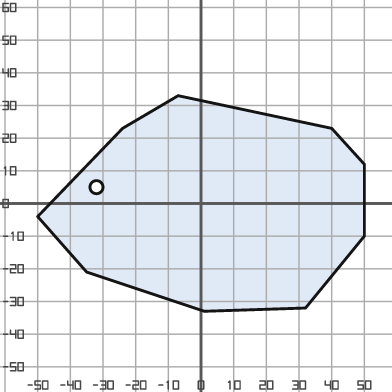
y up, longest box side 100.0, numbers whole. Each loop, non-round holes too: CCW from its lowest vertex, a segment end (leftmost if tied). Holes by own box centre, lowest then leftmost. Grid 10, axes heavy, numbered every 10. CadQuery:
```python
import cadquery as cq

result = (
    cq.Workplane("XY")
    .moveTo(1.0, -33.0)
    .lineTo(32.0, -32.0)
    .lineTo(50.0, -10.0)
    .lineTo(50.0, 12.0)
    .lineTo(40.0, 23.0)
    .lineTo(-7.0, 33.0)
    .lineTo(-24.0, 23.0)
    .lineTo(-50.0, -4.0)
    .lineTo(-35.0, -21.0)
    .close()
    .moveTo(-32.0, 5.0)
    .circle(2.0)
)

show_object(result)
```